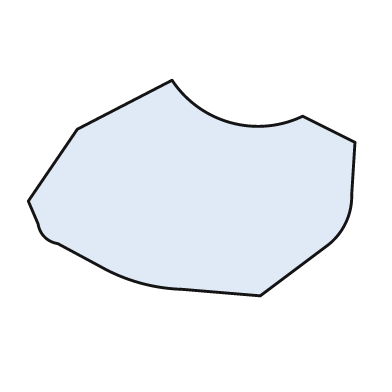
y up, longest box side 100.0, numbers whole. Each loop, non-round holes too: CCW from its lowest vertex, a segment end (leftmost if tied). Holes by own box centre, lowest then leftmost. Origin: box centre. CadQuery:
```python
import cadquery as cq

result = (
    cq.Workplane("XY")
    .moveTo(21.0, -33.0)
    .lineTo(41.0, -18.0)
    .threePointArc((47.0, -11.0), (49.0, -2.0))
    .lineTo(50.0, 14.0)
    .lineTo(34.0, 22.0)
    .threePointArc((12.0, 20.0), (-6.0, 33.0))
    .lineTo(-35.0, 18.0)
    .lineTo(-50.0, -4.0)
    .lineTo(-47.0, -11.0)
    .threePointArc((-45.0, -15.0), (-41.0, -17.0))
    .lineTo(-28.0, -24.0)
    .threePointArc((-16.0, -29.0), (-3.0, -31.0))
    .close()
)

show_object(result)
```